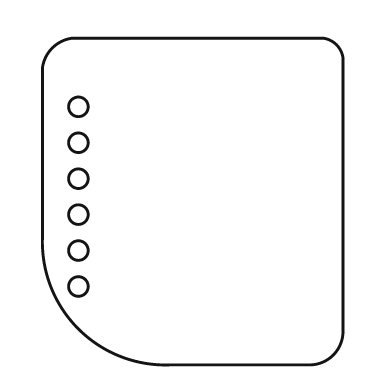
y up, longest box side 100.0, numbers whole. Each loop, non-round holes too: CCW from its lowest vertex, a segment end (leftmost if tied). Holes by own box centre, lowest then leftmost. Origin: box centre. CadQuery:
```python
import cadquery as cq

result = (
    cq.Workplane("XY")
    .moveTo(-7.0, -50.0)
    .lineTo(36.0, -50.0)
    .threePointArc((43.0, -47.0), (46.0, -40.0))
    .lineTo(46.0, 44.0)
    .threePointArc((44.0, 48.0), (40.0, 50.0))
    .lineTo(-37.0, 50.0)
    .threePointArc((-43.0, 47.0), (-46.0, 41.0))
    .lineTo(-46.0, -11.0)
    .threePointArc((-35.0, -39.0), (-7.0, -50.0))
    .close()
    .moveTo(-35.0, -26.0)
    .circle(3.0)
    .moveTo(-35.0, -15.0)
    .circle(3.0)
    .moveTo(-35.0, -4.0)
    .circle(3.0)
    .moveTo(-35.0, 7.0)
    .circle(3.0)
    .moveTo(-35.0, 18.0)
    .circle(3.0)
    .moveTo(-35.0, 29.0)
    .circle(3.0)
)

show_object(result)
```